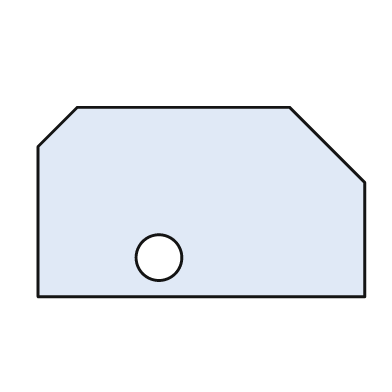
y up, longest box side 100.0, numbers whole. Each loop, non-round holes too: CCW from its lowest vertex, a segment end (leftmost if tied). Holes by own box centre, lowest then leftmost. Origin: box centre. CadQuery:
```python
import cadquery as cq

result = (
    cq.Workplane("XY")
    .moveTo(-50.0, -29.0)
    .lineTo(50.0, -29.0)
    .lineTo(50.0, 6.0)
    .lineTo(27.0, 29.0)
    .lineTo(-38.0, 29.0)
    .lineTo(-50.0, 17.0)
    .close()
    .moveTo(-13.0, -17.0)
    .circle(7.0)
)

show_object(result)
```